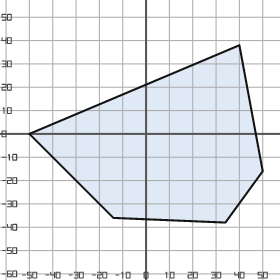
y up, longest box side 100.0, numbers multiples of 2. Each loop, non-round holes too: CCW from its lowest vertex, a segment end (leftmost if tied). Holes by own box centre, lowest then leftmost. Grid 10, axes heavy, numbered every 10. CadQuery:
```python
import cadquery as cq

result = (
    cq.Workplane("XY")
    .moveTo(34.0, -38.0)
    .lineTo(50.0, -16.0)
    .lineTo(40.0, 38.0)
    .lineTo(-50.0, 0.0)
    .lineTo(-14.0, -36.0)
    .close()
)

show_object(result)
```